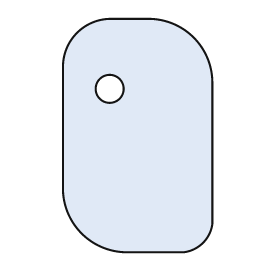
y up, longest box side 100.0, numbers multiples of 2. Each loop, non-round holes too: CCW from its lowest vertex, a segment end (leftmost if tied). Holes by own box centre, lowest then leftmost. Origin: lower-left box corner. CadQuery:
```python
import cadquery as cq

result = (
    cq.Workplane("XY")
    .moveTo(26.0, 0.0)
    .lineTo(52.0, 0.0)
    .threePointArc((60.0, 4.0), (64.0, 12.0))
    .lineTo(64.0, 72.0)
    .threePointArc((56.0, 92.0), (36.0, 100.0))
    .lineTo(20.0, 100.0)
    .threePointArc((6.0, 94.0), (0.0, 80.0))
    .lineTo(0.0, 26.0)
    .threePointArc((8.0, 8.0), (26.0, 0.0))
    .close()
    .moveTo(20.0, 70.0)
    .circle(6.0)
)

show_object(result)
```